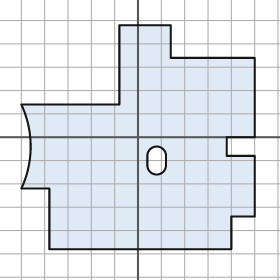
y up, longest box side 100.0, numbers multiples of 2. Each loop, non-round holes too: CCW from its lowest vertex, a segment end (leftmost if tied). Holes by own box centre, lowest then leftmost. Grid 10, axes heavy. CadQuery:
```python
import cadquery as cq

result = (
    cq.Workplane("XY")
    .moveTo(-38.0, -48.0)
    .lineTo(40.0, -48.0)
    .lineTo(40.0, -34.0)
    .lineTo(50.0, -34.0)
    .lineTo(50.0, -8.0)
    .lineTo(38.0, -8.0)
    .lineTo(38.0, 0.0)
    .lineTo(50.0, 0.0)
    .lineTo(50.0, 34.0)
    .lineTo(14.0, 34.0)
    .lineTo(14.0, 48.0)
    .lineTo(-8.0, 48.0)
    .lineTo(-8.0, 14.0)
    .lineTo(-50.0, 14.0)
    .threePointArc((-46.0, -4.0), (-50.0, -22.0))
    .lineTo(-38.0, -22.0)
    .close()
    .moveTo(4.0, -12.0)
    .threePointArc((8.0, -16.0), (12.0, -12.0))
    .lineTo(12.0, -8.0)
    .threePointArc((8.0, -4.0), (4.0, -8.0))
    .close()
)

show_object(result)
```